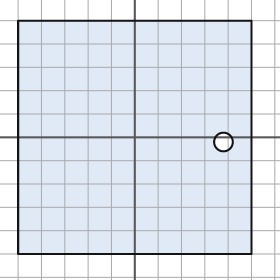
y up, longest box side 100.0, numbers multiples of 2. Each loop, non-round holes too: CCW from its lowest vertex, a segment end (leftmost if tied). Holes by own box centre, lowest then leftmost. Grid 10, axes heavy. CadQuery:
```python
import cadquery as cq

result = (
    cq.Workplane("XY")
    .moveTo(-50.0, -50.0)
    .lineTo(50.0, -50.0)
    .lineTo(50.0, 50.0)
    .lineTo(-50.0, 50.0)
    .close()
    .moveTo(38.0, -2.0)
    .circle(4.0)
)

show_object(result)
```